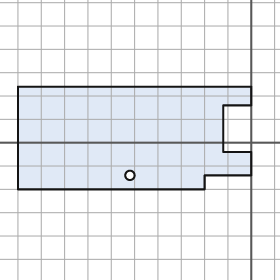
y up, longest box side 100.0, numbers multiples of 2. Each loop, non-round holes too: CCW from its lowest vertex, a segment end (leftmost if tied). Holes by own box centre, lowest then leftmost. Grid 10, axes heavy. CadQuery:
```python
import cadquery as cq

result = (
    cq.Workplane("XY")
    .moveTo(-100.0, -20.0)
    .lineTo(-20.0, -20.0)
    .lineTo(-20.0, -14.0)
    .lineTo(0.0, -14.0)
    .lineTo(0.0, -4.0)
    .lineTo(-12.0, -4.0)
    .lineTo(-12.0, 16.0)
    .lineTo(0.0, 16.0)
    .lineTo(0.0, 24.0)
    .lineTo(-100.0, 24.0)
    .close()
    .moveTo(-52.0, -14.0)
    .circle(2.0)
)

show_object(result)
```